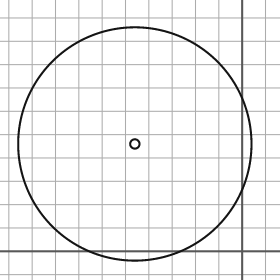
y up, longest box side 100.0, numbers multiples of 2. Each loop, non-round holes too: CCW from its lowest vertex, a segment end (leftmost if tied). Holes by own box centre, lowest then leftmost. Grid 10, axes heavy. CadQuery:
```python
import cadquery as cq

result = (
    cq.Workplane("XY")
    .moveTo(-46.0, 46.0)
    .circle(50.0)
    .moveTo(-46.0, 46.0)
    .circle(2.0)
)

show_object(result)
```